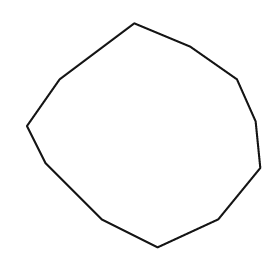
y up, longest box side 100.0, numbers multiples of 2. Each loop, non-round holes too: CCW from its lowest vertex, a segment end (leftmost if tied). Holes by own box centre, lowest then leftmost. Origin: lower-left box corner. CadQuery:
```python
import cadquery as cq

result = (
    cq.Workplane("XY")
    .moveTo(56.0, 0.0)
    .lineTo(82.0, 12.0)
    .lineTo(100.0, 34.0)
    .lineTo(98.0, 54.0)
    .lineTo(90.0, 72.0)
    .lineTo(70.0, 86.0)
    .lineTo(46.0, 96.0)
    .lineTo(14.0, 72.0)
    .lineTo(0.0, 52.0)
    .lineTo(8.0, 36.0)
    .lineTo(32.0, 12.0)
    .close()
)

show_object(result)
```